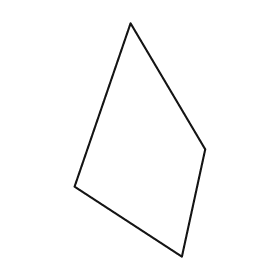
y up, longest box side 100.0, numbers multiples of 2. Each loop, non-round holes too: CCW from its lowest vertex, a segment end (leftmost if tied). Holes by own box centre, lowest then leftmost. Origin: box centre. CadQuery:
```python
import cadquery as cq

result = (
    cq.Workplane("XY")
    .moveTo(18.0, -50.0)
    .lineTo(28.0, -4.0)
    .lineTo(-4.0, 50.0)
    .lineTo(-28.0, -20.0)
    .close()
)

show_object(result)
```